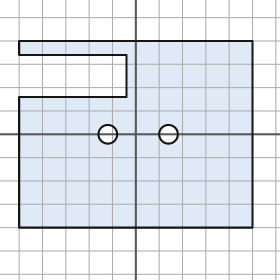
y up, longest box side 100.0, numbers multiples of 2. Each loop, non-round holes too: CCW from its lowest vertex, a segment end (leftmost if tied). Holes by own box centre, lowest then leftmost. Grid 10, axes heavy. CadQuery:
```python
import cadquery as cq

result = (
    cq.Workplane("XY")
    .moveTo(-50.0, -40.0)
    .lineTo(50.0, -40.0)
    .lineTo(50.0, 40.0)
    .lineTo(-50.0, 40.0)
    .lineTo(-50.0, 34.0)
    .lineTo(-4.0, 34.0)
    .lineTo(-4.0, 16.0)
    .lineTo(-50.0, 16.0)
    .close()
    .moveTo(-12.0, 0.0)
    .circle(4.0)
    .moveTo(14.0, 0.0)
    .circle(4.0)
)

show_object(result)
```